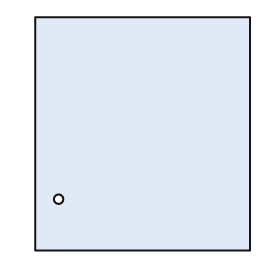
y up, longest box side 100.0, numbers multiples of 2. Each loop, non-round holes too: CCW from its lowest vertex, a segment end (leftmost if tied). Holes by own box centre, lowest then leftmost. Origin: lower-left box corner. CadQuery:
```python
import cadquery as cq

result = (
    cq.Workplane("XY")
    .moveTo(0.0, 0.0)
    .lineTo(92.0, 0.0)
    .lineTo(92.0, 100.0)
    .lineTo(0.0, 100.0)
    .close()
    .moveTo(10.0, 22.0)
    .circle(2.0)
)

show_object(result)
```